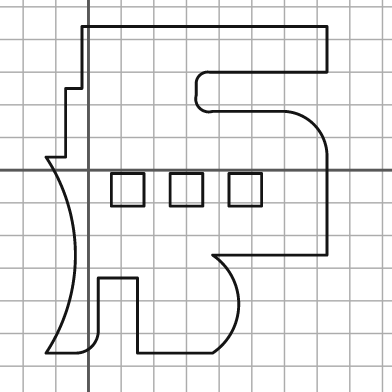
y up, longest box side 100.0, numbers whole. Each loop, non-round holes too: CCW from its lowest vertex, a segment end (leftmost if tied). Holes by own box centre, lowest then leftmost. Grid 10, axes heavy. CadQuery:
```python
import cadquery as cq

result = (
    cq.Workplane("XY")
    .moveTo(-13.0, -56.0)
    .lineTo(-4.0, -56.0)
    .threePointArc((1.0, -54.0), (3.0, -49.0))
    .lineTo(3.0, -33.0)
    .lineTo(15.0, -33.0)
    .lineTo(15.0, -56.0)
    .lineTo(38.0, -56.0)
    .threePointArc((46.0, -41.0), (38.0, -26.0))
    .lineTo(73.0, -26.0)
    .lineTo(73.0, 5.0)
    .threePointArc((69.0, 14.0), (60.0, 18.0))
    .lineTo(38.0, 18.0)
    .threePointArc((34.0, 19.0), (33.0, 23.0))
    .lineTo(33.0, 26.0)
    .threePointArc((34.0, 29.0), (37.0, 30.0))
    .lineTo(73.0, 30.0)
    .lineTo(73.0, 44.0)
    .lineTo(-2.0, 44.0)
    .lineTo(-2.0, 25.0)
    .lineTo(-7.0, 25.0)
    .lineTo(-7.0, 4.0)
    .lineTo(-13.0, 4.0)
    .threePointArc((-4.0, -26.0), (-13.0, -56.0))
    .close()
    .moveTo(7.0, -11.0)
    .lineTo(17.0, -11.0)
    .lineTo(17.0, -1.0)
    .lineTo(7.0, -1.0)
    .close()
    .moveTo(25.0, -11.0)
    .lineTo(35.0, -11.0)
    .lineTo(35.0, -1.0)
    .lineTo(25.0, -1.0)
    .close()
    .moveTo(43.0, -11.0)
    .lineTo(53.0, -11.0)
    .lineTo(53.0, -1.0)
    .lineTo(43.0, -1.0)
    .close()
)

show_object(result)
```